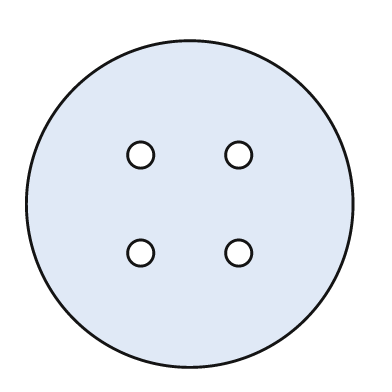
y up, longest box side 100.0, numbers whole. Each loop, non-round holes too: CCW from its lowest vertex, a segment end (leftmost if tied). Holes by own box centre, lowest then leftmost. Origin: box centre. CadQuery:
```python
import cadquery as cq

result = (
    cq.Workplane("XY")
    .moveTo(0.0, 0.0)
    .circle(50.0)
    .moveTo(-15.0, -15.0)
    .circle(4.0)
    .moveTo(15.0, -15.0)
    .circle(4.0)
    .moveTo(-15.0, 15.0)
    .circle(4.0)
    .moveTo(15.0, 15.0)
    .circle(4.0)
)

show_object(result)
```